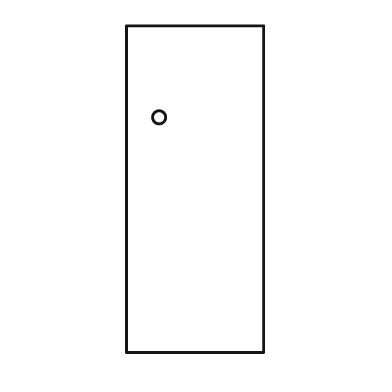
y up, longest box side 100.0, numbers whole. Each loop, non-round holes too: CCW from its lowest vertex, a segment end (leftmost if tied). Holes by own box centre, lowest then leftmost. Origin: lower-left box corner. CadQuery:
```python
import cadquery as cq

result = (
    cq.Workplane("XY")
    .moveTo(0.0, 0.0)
    .lineTo(42.0, 0.0)
    .lineTo(42.0, 100.0)
    .lineTo(0.0, 100.0)
    .close()
    .moveTo(10.0, 72.0)
    .circle(2.0)
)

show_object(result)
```